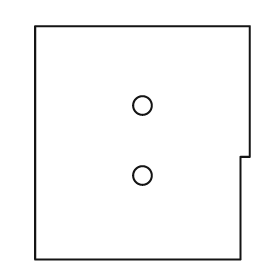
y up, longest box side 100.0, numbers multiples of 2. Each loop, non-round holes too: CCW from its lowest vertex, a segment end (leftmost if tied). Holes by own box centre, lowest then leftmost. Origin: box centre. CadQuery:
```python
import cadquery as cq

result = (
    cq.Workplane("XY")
    .moveTo(-46.0, -50.0)
    .lineTo(42.0, -50.0)
    .lineTo(42.0, -6.0)
    .lineTo(46.0, -6.0)
    .lineTo(46.0, 50.0)
    .lineTo(-46.0, 50.0)
    .close()
    .moveTo(0.0, -14.0)
    .circle(4.0)
    .moveTo(0.0, 16.0)
    .circle(4.0)
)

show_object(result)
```